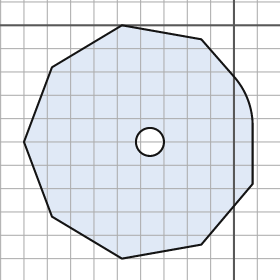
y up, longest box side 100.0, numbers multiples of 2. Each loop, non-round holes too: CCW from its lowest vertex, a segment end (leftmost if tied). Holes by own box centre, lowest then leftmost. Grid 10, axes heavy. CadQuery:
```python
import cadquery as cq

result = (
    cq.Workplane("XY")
    .moveTo(-48.0, -100.0)
    .lineTo(-14.0, -94.0)
    .lineTo(8.0, -68.0)
    .lineTo(8.0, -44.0)
    .threePointArc((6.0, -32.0), (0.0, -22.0))
    .lineTo(-14.0, -6.0)
    .lineTo(-48.0, 0.0)
    .lineTo(-78.0, -18.0)
    .lineTo(-90.0, -50.0)
    .lineTo(-78.0, -82.0)
    .close()
    .moveTo(-36.0, -50.0)
    .circle(6.0)
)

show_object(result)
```